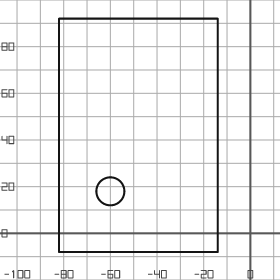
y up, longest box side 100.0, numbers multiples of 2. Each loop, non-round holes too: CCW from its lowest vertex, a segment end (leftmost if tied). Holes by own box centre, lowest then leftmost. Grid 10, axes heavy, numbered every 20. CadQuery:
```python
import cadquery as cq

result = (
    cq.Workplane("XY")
    .moveTo(-82.0, -8.0)
    .lineTo(-14.0, -8.0)
    .lineTo(-14.0, 92.0)
    .lineTo(-82.0, 92.0)
    .close()
    .moveTo(-60.0, 18.0)
    .circle(6.0)
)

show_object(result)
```